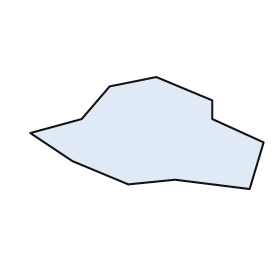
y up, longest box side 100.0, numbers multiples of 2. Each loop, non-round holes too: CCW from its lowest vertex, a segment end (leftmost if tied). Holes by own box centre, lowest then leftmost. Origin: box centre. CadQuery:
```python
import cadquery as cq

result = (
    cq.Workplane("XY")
    .moveTo(44.0, -24.0)
    .lineTo(50.0, -4.0)
    .lineTo(28.0, 6.0)
    .lineTo(28.0, 14.0)
    .lineTo(4.0, 24.0)
    .lineTo(-16.0, 20.0)
    .lineTo(-28.0, 6.0)
    .lineTo(-50.0, 0.0)
    .lineTo(-32.0, -12.0)
    .lineTo(-8.0, -22.0)
    .lineTo(12.0, -20.0)
    .close()
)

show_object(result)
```